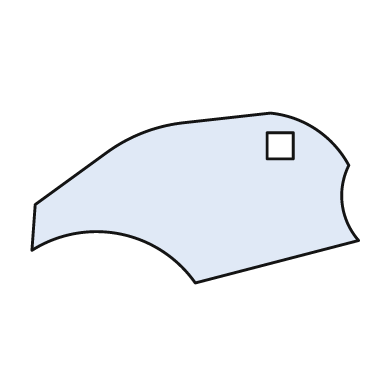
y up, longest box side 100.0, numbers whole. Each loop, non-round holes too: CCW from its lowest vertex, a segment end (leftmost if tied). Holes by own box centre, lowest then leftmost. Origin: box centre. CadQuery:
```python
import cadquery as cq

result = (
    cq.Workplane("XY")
    .moveTo(0.0, -26.0)
    .lineTo(50.0, -13.0)
    .threePointArc((45.0, -2.0), (47.0, 10.0))
    .threePointArc((37.0, 21.0), (23.0, 26.0))
    .lineTo(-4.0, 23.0)
    .threePointArc((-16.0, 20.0), (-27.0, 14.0))
    .lineTo(-49.0, -2.0)
    .lineTo(-50.0, -16.0)
    .threePointArc((-23.0, -11.0), (0.0, -26.0))
    .close()
    .moveTo(22.0, 12.0)
    .lineTo(30.0, 12.0)
    .lineTo(30.0, 20.0)
    .lineTo(22.0, 20.0)
    .close()
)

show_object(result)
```